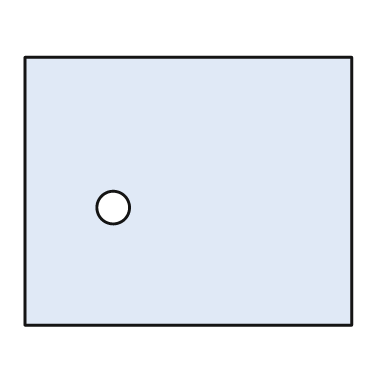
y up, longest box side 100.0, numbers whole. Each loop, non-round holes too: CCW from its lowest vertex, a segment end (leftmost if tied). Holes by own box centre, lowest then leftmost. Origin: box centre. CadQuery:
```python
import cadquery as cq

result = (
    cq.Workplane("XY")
    .moveTo(-50.0, -41.0)
    .lineTo(50.0, -41.0)
    .lineTo(50.0, 41.0)
    .lineTo(-50.0, 41.0)
    .close()
    .moveTo(-23.0, -5.0)
    .circle(5.0)
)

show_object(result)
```